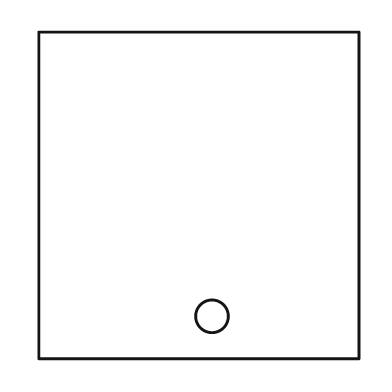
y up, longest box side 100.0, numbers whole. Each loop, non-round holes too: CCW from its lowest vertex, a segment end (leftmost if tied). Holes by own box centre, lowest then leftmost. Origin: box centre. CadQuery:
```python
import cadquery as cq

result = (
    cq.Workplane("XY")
    .moveTo(-49.0, -50.0)
    .lineTo(49.0, -50.0)
    .lineTo(49.0, 50.0)
    .lineTo(-49.0, 50.0)
    .close()
    .moveTo(4.0, -37.0)
    .circle(5.0)
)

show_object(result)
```